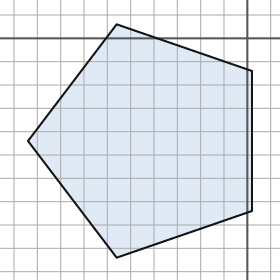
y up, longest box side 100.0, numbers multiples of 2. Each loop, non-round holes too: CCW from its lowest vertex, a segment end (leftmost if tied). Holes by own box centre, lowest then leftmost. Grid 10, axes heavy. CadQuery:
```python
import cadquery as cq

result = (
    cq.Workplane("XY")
    .moveTo(-56.0, -94.0)
    .lineTo(2.0, -74.0)
    .lineTo(2.0, -14.0)
    .lineTo(-56.0, 6.0)
    .lineTo(-94.0, -44.0)
    .close()
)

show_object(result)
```